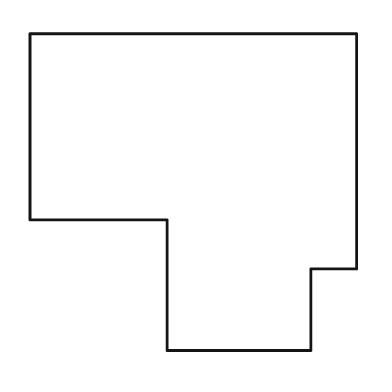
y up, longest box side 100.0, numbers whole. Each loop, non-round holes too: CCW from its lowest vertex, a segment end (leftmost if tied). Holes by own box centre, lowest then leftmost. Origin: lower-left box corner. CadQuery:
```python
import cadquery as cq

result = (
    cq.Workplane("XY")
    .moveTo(42.0, 0.0)
    .lineTo(86.0, 0.0)
    .lineTo(86.0, 25.0)
    .lineTo(100.0, 25.0)
    .lineTo(100.0, 97.0)
    .lineTo(0.0, 97.0)
    .lineTo(0.0, 40.0)
    .lineTo(42.0, 40.0)
    .close()
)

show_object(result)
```